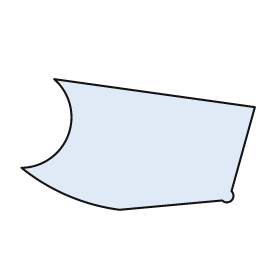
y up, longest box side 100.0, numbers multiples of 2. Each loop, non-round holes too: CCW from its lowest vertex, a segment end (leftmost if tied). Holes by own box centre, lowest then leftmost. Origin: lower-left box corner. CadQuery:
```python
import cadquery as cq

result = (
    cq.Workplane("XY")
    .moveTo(42.0, 0.0)
    .lineTo(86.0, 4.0)
    .threePointArc((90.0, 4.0), (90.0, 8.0))
    .lineTo(100.0, 44.0)
    .lineTo(14.0, 56.0)
    .threePointArc((20.0, 32.0), (0.0, 18.0))
    .threePointArc((20.0, 6.0), (42.0, 0.0))
    .close()
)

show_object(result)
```